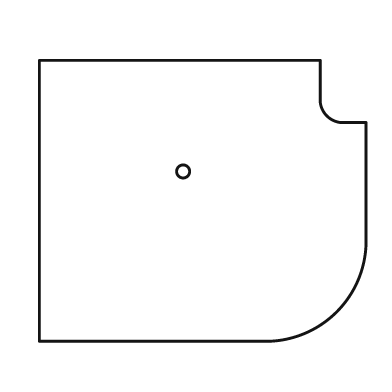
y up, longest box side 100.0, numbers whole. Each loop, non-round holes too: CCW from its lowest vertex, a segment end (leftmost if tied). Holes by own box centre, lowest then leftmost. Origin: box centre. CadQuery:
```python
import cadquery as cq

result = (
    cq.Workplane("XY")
    .moveTo(-50.0, -43.0)
    .lineTo(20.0, -43.0)
    .threePointArc((41.0, -34.0), (50.0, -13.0))
    .lineTo(50.0, 24.0)
    .lineTo(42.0, 24.0)
    .threePointArc((38.0, 26.0), (36.0, 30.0))
    .lineTo(36.0, 43.0)
    .lineTo(-50.0, 43.0)
    .close()
    .moveTo(-6.0, 9.0)
    .circle(2.0)
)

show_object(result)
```